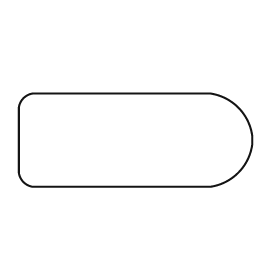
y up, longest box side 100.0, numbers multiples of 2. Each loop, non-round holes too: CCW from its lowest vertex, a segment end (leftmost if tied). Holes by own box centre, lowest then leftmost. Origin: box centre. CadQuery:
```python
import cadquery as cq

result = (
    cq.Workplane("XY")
    .moveTo(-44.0, -20.0)
    .lineTo(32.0, -20.0)
    .threePointArc((44.0, -14.0), (50.0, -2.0))
    .lineTo(50.0, 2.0)
    .threePointArc((44.0, 14.0), (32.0, 20.0))
    .lineTo(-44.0, 20.0)
    .threePointArc((-48.0, 18.0), (-50.0, 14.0))
    .lineTo(-50.0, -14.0)
    .threePointArc((-48.0, -18.0), (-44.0, -20.0))
    .close()
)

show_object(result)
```